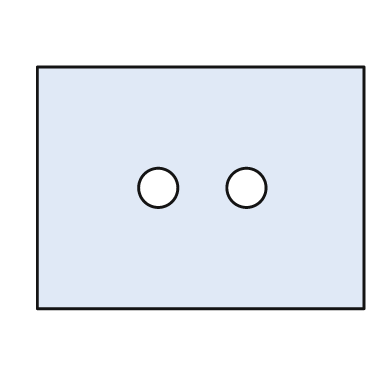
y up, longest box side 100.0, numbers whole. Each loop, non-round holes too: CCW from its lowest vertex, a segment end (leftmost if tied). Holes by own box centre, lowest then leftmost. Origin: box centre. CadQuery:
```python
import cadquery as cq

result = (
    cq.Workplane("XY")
    .moveTo(-50.0, -37.0)
    .lineTo(50.0, -37.0)
    .lineTo(50.0, 37.0)
    .lineTo(-50.0, 37.0)
    .close()
    .moveTo(-13.0, 0.0)
    .circle(6.0)
    .moveTo(14.0, 0.0)
    .circle(6.0)
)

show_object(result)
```